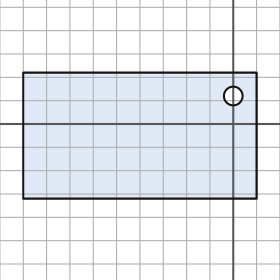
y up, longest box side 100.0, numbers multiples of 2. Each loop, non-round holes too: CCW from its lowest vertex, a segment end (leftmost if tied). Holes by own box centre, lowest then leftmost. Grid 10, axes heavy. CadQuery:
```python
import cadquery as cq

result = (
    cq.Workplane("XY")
    .moveTo(-90.0, -32.0)
    .lineTo(10.0, -32.0)
    .lineTo(10.0, 22.0)
    .lineTo(-90.0, 22.0)
    .close()
    .moveTo(0.0, 12.0)
    .circle(4.0)
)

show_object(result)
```